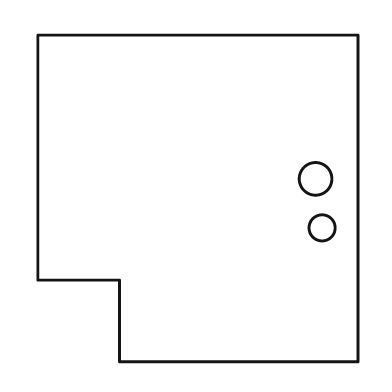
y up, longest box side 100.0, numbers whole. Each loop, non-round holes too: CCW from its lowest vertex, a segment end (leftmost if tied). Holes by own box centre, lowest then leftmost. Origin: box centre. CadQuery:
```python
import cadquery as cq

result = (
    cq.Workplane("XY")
    .moveTo(-24.0, -50.0)
    .lineTo(49.0, -50.0)
    .lineTo(49.0, 50.0)
    .lineTo(-49.0, 50.0)
    .lineTo(-49.0, -25.0)
    .lineTo(-24.0, -25.0)
    .close()
    .moveTo(38.0, -9.0)
    .circle(4.0)
    .moveTo(36.0, 6.0)
    .circle(5.0)
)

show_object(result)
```